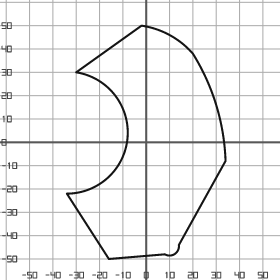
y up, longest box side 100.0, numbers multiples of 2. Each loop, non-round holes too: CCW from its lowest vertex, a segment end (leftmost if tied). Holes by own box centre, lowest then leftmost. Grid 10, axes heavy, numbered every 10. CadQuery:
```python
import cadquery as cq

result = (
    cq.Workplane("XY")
    .moveTo(-16.0, -50.0)
    .lineTo(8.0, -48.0)
    .threePointArc((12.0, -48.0), (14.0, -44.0))
    .lineTo(34.0, -8.0)
    .threePointArc((30.0, 16.0), (20.0, 38.0))
    .threePointArc((10.0, 46.0), (-2.0, 50.0))
    .lineTo(-30.0, 30.0)
    .threePointArc((-8.0, 2.0), (-34.0, -22.0))
    .close()
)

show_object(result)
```